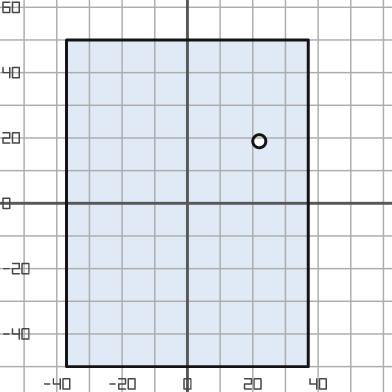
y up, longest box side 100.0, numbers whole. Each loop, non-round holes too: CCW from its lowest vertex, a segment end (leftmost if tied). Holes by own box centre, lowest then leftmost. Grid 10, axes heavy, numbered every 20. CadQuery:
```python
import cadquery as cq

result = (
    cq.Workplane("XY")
    .moveTo(-37.0, -50.0)
    .lineTo(37.0, -50.0)
    .lineTo(37.0, 50.0)
    .lineTo(-37.0, 50.0)
    .close()
    .moveTo(22.0, 19.0)
    .circle(2.0)
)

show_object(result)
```